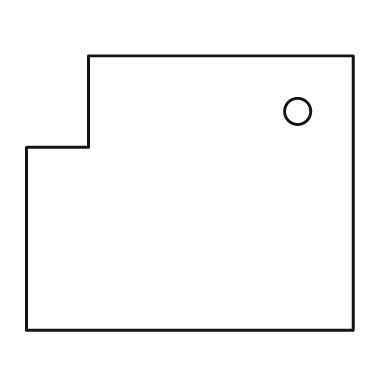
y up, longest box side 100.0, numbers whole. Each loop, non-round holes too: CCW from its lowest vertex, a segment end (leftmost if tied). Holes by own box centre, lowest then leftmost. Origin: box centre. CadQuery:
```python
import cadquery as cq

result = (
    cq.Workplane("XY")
    .moveTo(-50.0, -42.0)
    .lineTo(50.0, -42.0)
    .lineTo(50.0, 42.0)
    .lineTo(-31.0, 42.0)
    .lineTo(-31.0, 14.0)
    .lineTo(-50.0, 14.0)
    .close()
    .moveTo(33.0, 25.0)
    .circle(4.0)
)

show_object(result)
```